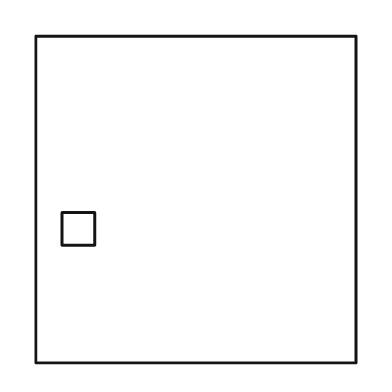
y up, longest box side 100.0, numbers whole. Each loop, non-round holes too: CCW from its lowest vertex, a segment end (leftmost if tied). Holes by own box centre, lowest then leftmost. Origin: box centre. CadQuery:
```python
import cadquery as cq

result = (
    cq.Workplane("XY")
    .moveTo(-49.0, -50.0)
    .lineTo(49.0, -50.0)
    .lineTo(49.0, 50.0)
    .lineTo(-49.0, 50.0)
    .close()
    .moveTo(-41.0, -14.0)
    .lineTo(-31.0, -14.0)
    .lineTo(-31.0, -4.0)
    .lineTo(-41.0, -4.0)
    .close()
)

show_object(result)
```